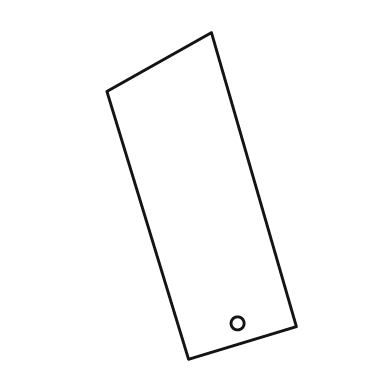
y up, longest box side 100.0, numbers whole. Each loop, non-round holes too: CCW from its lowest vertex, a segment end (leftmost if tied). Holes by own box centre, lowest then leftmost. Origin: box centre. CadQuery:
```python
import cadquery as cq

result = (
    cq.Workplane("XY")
    .moveTo(-4.0, -50.0)
    .lineTo(29.0, -40.0)
    .lineTo(3.0, 50.0)
    .lineTo(-29.0, 32.0)
    .close()
    .moveTo(11.0, -39.0)
    .circle(2.0)
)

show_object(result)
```